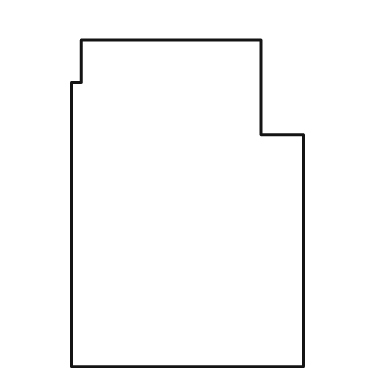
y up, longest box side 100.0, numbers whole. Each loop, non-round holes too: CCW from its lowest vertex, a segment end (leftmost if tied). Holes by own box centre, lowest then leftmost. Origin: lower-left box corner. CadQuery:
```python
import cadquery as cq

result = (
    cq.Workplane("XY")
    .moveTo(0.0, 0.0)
    .lineTo(71.0, 0.0)
    .lineTo(71.0, 71.0)
    .lineTo(58.0, 71.0)
    .lineTo(58.0, 100.0)
    .lineTo(3.0, 100.0)
    .lineTo(3.0, 87.0)
    .lineTo(0.0, 87.0)
    .close()
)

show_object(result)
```